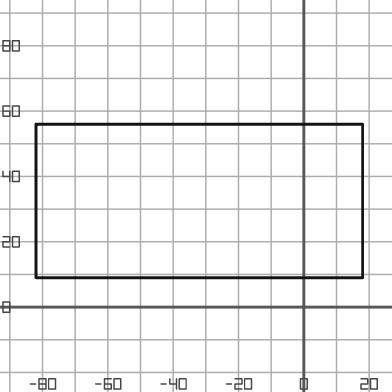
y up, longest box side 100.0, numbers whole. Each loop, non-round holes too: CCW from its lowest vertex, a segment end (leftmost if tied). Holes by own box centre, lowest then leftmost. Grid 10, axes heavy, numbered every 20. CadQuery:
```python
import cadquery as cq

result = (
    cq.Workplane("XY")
    .moveTo(-82.0, 9.0)
    .lineTo(18.0, 9.0)
    .lineTo(18.0, 56.0)
    .lineTo(-82.0, 56.0)
    .close()
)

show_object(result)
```